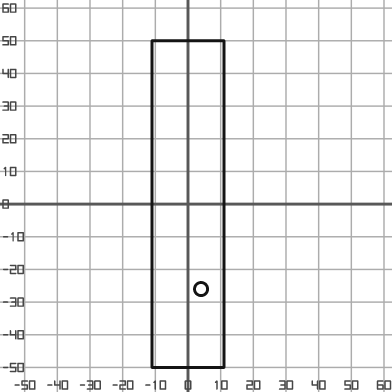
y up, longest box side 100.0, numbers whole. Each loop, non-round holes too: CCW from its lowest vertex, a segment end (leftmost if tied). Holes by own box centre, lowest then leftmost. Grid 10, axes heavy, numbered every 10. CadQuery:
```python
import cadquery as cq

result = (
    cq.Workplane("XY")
    .moveTo(-11.0, -50.0)
    .lineTo(11.0, -50.0)
    .lineTo(11.0, 50.0)
    .lineTo(-11.0, 50.0)
    .close()
    .moveTo(4.0, -26.0)
    .circle(2.0)
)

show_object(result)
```